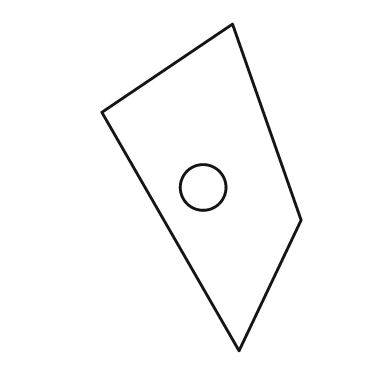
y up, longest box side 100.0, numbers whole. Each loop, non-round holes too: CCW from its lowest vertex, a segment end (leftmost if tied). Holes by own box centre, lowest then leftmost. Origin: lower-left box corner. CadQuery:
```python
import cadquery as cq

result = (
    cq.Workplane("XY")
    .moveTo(42.0, 0.0)
    .lineTo(61.0, 40.0)
    .lineTo(40.0, 100.0)
    .lineTo(0.0, 73.0)
    .close()
    .moveTo(31.0, 50.0)
    .circle(7.0)
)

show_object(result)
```